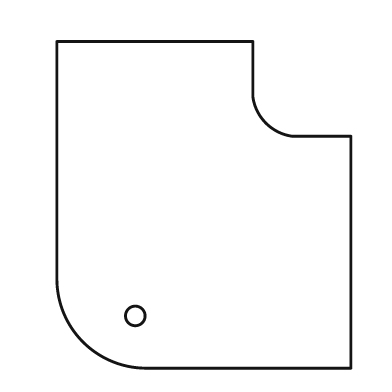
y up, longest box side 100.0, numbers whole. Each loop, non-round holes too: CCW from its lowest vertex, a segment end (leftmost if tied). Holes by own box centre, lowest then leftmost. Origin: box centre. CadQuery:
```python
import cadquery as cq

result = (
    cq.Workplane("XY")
    .moveTo(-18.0, -50.0)
    .lineTo(45.0, -50.0)
    .lineTo(45.0, 21.0)
    .lineTo(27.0, 21.0)
    .threePointArc((19.0, 25.0), (15.0, 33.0))
    .lineTo(15.0, 50.0)
    .lineTo(-45.0, 50.0)
    .lineTo(-45.0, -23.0)
    .threePointArc((-37.0, -42.0), (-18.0, -50.0))
    .close()
    .moveTo(-21.0, -34.0)
    .circle(3.0)
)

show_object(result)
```